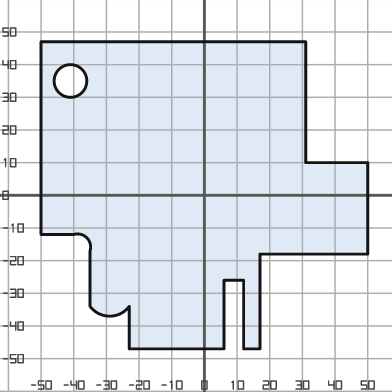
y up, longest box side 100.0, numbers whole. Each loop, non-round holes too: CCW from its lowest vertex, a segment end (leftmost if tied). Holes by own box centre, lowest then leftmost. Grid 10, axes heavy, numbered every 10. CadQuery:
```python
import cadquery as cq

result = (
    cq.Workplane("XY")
    .moveTo(-23.0, -47.0)
    .lineTo(6.0, -47.0)
    .lineTo(6.0, -26.0)
    .lineTo(12.0, -26.0)
    .lineTo(12.0, -47.0)
    .lineTo(17.0, -47.0)
    .lineTo(17.0, -18.0)
    .lineTo(50.0, -18.0)
    .lineTo(50.0, 10.0)
    .lineTo(31.0, 10.0)
    .lineTo(31.0, 47.0)
    .lineTo(-50.0, 47.0)
    .lineTo(-50.0, -12.0)
    .lineTo(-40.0, -12.0)
    .threePointArc((-36.0, -13.0), (-35.0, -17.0))
    .lineTo(-35.0, -34.0)
    .threePointArc((-29.0, -37.0), (-23.0, -34.0))
    .close()
    .moveTo(-41.0, 35.0)
    .circle(5.0)
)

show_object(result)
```